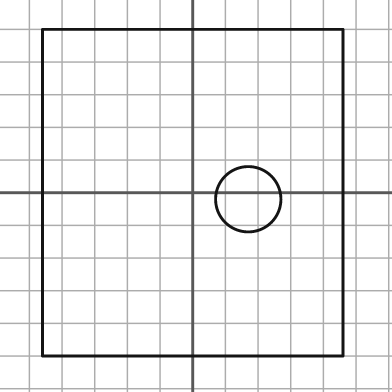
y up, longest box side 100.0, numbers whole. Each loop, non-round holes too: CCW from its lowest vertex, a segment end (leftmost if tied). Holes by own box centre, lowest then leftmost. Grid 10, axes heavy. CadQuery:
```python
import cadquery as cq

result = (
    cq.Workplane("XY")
    .moveTo(-46.0, -50.0)
    .lineTo(46.0, -50.0)
    .lineTo(46.0, 50.0)
    .lineTo(-46.0, 50.0)
    .close()
    .moveTo(17.0, -2.0)
    .circle(10.0)
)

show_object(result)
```